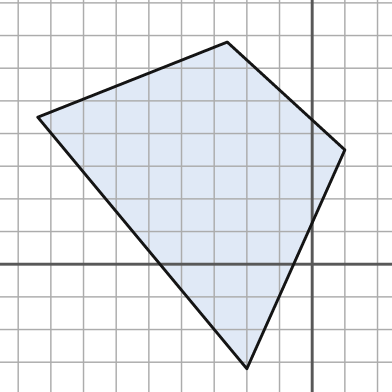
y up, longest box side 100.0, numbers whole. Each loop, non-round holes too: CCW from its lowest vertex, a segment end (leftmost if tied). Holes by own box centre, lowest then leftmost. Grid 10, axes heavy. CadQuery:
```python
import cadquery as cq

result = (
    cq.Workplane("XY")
    .moveTo(-20.0, -32.0)
    .lineTo(10.0, 35.0)
    .lineTo(-26.0, 68.0)
    .lineTo(-84.0, 45.0)
    .close()
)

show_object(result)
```